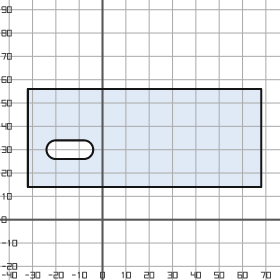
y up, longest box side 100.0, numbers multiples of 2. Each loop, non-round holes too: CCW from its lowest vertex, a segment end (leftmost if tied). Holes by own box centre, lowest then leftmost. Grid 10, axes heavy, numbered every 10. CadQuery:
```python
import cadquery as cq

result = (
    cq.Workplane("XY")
    .moveTo(-32.0, 14.0)
    .lineTo(68.0, 14.0)
    .lineTo(68.0, 56.0)
    .lineTo(-32.0, 56.0)
    .close()
    .moveTo(-20.0, 26.0)
    .lineTo(-8.0, 26.0)
    .threePointArc((-4.0, 30.0), (-8.0, 34.0))
    .lineTo(-20.0, 34.0)
    .threePointArc((-24.0, 30.0), (-20.0, 26.0))
    .close()
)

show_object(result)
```